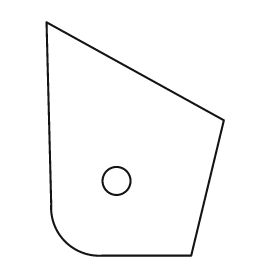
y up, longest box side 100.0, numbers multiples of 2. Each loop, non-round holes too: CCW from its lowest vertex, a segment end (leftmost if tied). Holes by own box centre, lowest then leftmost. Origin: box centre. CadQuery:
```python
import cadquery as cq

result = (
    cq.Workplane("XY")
    .moveTo(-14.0, -50.0)
    .lineTo(24.0, -50.0)
    .lineTo(38.0, 8.0)
    .lineTo(-38.0, 50.0)
    .lineTo(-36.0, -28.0)
    .threePointArc((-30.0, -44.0), (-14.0, -50.0))
    .close()
    .moveTo(-8.0, -18.0)
    .circle(6.0)
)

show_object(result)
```